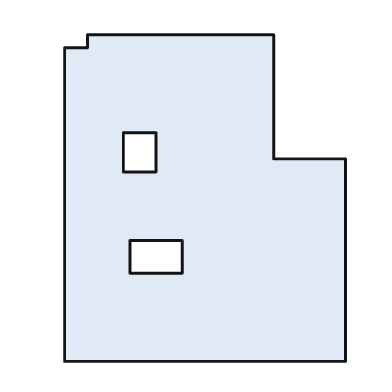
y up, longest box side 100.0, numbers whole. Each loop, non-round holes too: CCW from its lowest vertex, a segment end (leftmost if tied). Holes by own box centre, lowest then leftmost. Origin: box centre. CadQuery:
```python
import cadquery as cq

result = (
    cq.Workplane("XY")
    .moveTo(-43.0, -50.0)
    .lineTo(43.0, -50.0)
    .lineTo(43.0, 12.0)
    .lineTo(21.0, 12.0)
    .lineTo(21.0, 50.0)
    .lineTo(-36.0, 50.0)
    .lineTo(-36.0, 46.0)
    .lineTo(-43.0, 46.0)
    .close()
    .moveTo(-23.0, -23.0)
    .lineTo(-7.0, -23.0)
    .lineTo(-7.0, -13.0)
    .lineTo(-23.0, -13.0)
    .close()
    .moveTo(-25.0, 8.0)
    .lineTo(-15.0, 8.0)
    .lineTo(-15.0, 20.0)
    .lineTo(-25.0, 20.0)
    .close()
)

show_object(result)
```